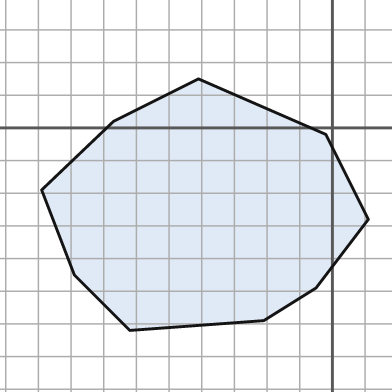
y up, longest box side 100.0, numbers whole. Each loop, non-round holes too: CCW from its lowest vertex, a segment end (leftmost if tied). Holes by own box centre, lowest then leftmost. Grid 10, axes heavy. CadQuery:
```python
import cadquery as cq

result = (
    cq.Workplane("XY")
    .moveTo(-62.0, -62.0)
    .lineTo(-21.0, -59.0)
    .lineTo(-5.0, -49.0)
    .lineTo(11.0, -28.0)
    .lineTo(-2.0, -2.0)
    .lineTo(-41.0, 15.0)
    .lineTo(-67.0, 2.0)
    .lineTo(-89.0, -19.0)
    .lineTo(-79.0, -45.0)
    .close()
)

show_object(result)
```